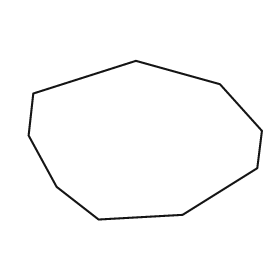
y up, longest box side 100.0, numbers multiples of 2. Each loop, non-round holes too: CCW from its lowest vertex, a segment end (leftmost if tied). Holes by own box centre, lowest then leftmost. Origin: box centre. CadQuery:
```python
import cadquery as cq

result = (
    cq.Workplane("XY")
    .moveTo(-20.0, -34.0)
    .lineTo(16.0, -32.0)
    .lineTo(48.0, -12.0)
    .lineTo(50.0, 4.0)
    .lineTo(32.0, 24.0)
    .lineTo(-4.0, 34.0)
    .lineTo(-48.0, 20.0)
    .lineTo(-50.0, 2.0)
    .lineTo(-38.0, -20.0)
    .close()
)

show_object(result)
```